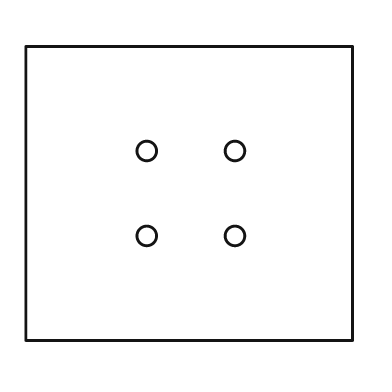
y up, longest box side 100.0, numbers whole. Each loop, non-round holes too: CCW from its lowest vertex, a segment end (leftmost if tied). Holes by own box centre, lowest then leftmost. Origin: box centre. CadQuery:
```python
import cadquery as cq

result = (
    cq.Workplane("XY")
    .moveTo(-50.0, -45.0)
    .lineTo(50.0, -45.0)
    .lineTo(50.0, 45.0)
    .lineTo(-50.0, 45.0)
    .close()
    .moveTo(-13.0, -13.0)
    .circle(3.0)
    .moveTo(14.0, -13.0)
    .circle(3.0)
    .moveTo(-13.0, 13.0)
    .circle(3.0)
    .moveTo(14.0, 13.0)
    .circle(3.0)
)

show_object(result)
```